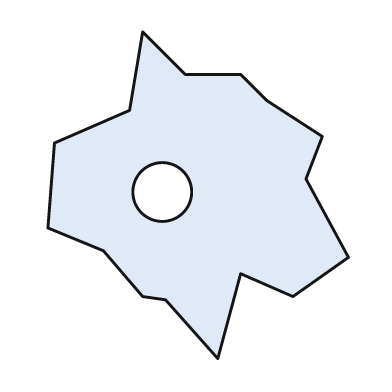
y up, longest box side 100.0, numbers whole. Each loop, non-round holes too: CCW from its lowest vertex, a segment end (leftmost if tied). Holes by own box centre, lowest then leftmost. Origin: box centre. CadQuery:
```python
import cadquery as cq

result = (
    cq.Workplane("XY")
    .moveTo(6.0, -50.0)
    .lineTo(13.0, -24.0)
    .lineTo(29.0, -31.0)
    .lineTo(46.0, -19.0)
    .lineTo(33.0, 5.0)
    .lineTo(38.0, 18.0)
    .lineTo(21.0, 29.0)
    .lineTo(13.0, 37.0)
    .lineTo(-4.0, 37.0)
    .lineTo(-17.0, 50.0)
    .lineTo(-21.0, 26.0)
    .lineTo(-44.0, 16.0)
    .lineTo(-46.0, -10.0)
    .lineTo(-29.0, -17.0)
    .lineTo(-17.0, -31.0)
    .lineTo(-10.0, -32.0)
    .close()
    .moveTo(-11.0, 1.0)
    .circle(9.0)
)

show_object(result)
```